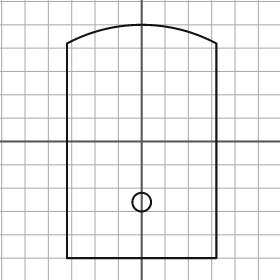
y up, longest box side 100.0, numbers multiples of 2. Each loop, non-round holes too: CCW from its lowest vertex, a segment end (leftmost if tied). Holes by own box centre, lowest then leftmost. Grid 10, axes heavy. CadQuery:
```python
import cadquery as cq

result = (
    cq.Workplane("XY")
    .moveTo(-32.0, -50.0)
    .lineTo(32.0, -50.0)
    .lineTo(32.0, 42.0)
    .threePointArc((0.0, 50.0), (-32.0, 42.0))
    .close()
    .moveTo(0.0, -26.0)
    .circle(4.0)
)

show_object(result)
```